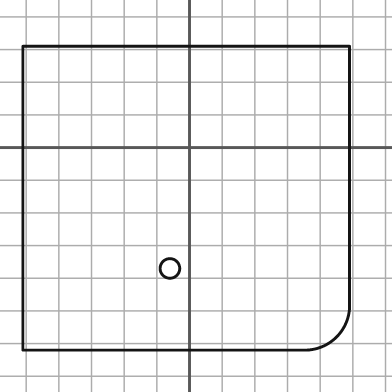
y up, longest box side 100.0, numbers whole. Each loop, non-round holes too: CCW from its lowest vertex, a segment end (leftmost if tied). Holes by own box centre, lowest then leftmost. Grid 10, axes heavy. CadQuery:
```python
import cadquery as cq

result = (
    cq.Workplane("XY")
    .moveTo(-51.0, -62.0)
    .lineTo(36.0, -62.0)
    .threePointArc((45.0, -58.0), (49.0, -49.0))
    .lineTo(49.0, 31.0)
    .lineTo(-51.0, 31.0)
    .close()
    .moveTo(-6.0, -37.0)
    .circle(3.0)
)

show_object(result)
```